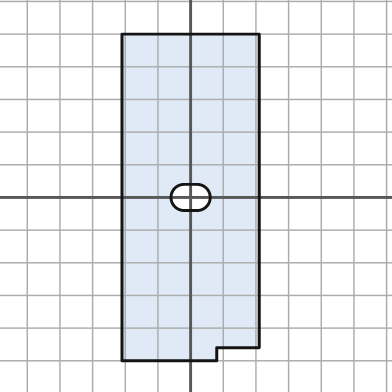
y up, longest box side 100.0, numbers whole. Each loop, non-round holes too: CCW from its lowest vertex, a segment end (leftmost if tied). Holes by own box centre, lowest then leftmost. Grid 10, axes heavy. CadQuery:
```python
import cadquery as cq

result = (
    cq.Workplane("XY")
    .moveTo(-21.0, -50.0)
    .lineTo(8.0, -50.0)
    .lineTo(8.0, -46.0)
    .lineTo(21.0, -46.0)
    .lineTo(21.0, 50.0)
    .lineTo(-21.0, 50.0)
    .close()
    .moveTo(-2.0, -4.0)
    .lineTo(2.0, -4.0)
    .threePointArc((6.0, 0.0), (2.0, 4.0))
    .lineTo(-2.0, 4.0)
    .threePointArc((-6.0, 0.0), (-2.0, -4.0))
    .close()
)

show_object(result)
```